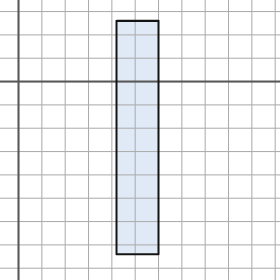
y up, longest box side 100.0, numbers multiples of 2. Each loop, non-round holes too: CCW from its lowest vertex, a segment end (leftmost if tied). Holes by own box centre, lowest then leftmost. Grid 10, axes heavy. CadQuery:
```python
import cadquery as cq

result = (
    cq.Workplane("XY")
    .moveTo(42.0, -74.0)
    .lineTo(60.0, -74.0)
    .lineTo(60.0, 26.0)
    .lineTo(42.0, 26.0)
    .close()
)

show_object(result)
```